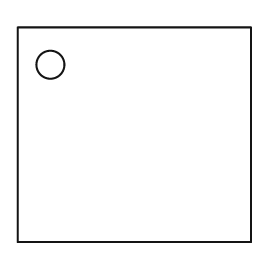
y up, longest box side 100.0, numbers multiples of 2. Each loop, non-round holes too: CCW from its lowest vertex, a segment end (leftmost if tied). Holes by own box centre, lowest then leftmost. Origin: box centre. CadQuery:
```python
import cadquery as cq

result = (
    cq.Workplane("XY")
    .moveTo(-50.0, -46.0)
    .lineTo(50.0, -46.0)
    .lineTo(50.0, 46.0)
    .lineTo(-50.0, 46.0)
    .close()
    .moveTo(-36.0, 30.0)
    .circle(6.0)
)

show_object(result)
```